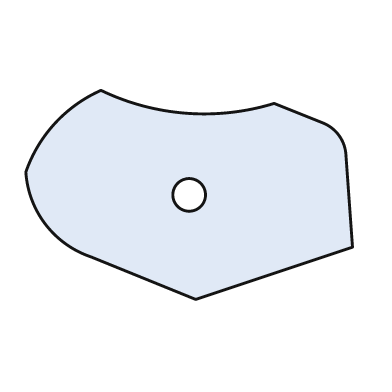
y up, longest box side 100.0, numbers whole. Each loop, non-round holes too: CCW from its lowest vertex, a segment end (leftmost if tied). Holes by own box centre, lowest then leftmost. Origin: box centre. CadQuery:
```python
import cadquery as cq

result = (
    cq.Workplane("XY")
    .moveTo(2.0, -32.0)
    .lineTo(50.0, -16.0)
    .lineTo(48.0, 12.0)
    .threePointArc((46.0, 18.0), (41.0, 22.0))
    .lineTo(26.0, 28.0)
    .threePointArc((-1.0, 25.0), (-27.0, 32.0))
    .threePointArc((-41.0, 22.0), (-50.0, 7.0))
    .threePointArc((-44.0, -9.0), (-30.0, -19.0))
    .close()
    .moveTo(0.0, 0.0)
    .circle(5.0)
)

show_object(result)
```